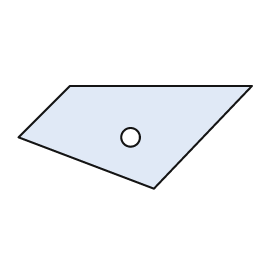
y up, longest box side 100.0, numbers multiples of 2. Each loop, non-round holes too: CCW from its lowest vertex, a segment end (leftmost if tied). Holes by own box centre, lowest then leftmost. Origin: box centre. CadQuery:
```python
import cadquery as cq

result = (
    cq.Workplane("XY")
    .moveTo(8.0, -22.0)
    .lineTo(50.0, 22.0)
    .lineTo(-28.0, 22.0)
    .lineTo(-50.0, 0.0)
    .close()
    .moveTo(-2.0, 0.0)
    .circle(4.0)
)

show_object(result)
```